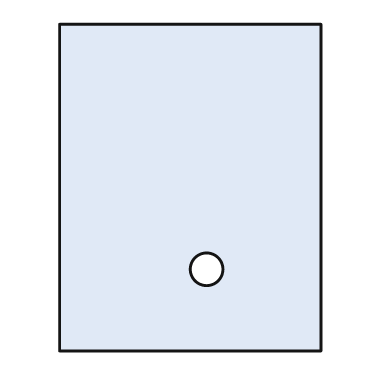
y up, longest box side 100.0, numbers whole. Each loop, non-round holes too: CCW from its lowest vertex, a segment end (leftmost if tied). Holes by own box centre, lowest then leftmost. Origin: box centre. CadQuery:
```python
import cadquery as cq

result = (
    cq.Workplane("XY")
    .moveTo(-40.0, -50.0)
    .lineTo(40.0, -50.0)
    .lineTo(40.0, 50.0)
    .lineTo(-40.0, 50.0)
    .close()
    .moveTo(5.0, -25.0)
    .circle(5.0)
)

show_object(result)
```